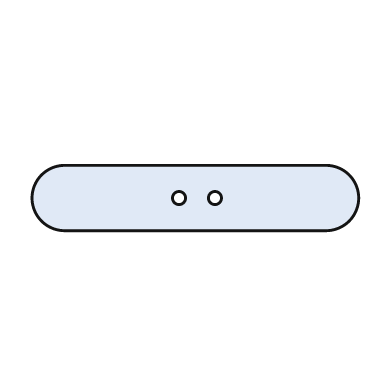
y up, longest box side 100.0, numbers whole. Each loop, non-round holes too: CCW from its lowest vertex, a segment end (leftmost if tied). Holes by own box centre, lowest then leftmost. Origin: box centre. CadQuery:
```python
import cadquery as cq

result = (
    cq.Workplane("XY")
    .moveTo(-40.0, -10.0)
    .lineTo(40.0, -10.0)
    .threePointArc((50.0, 0.0), (40.0, 10.0))
    .lineTo(-40.0, 10.0)
    .threePointArc((-50.0, 0.0), (-40.0, -10.0))
    .close()
    .moveTo(-5.0, 0.0)
    .circle(2.0)
    .moveTo(6.0, 0.0)
    .circle(2.0)
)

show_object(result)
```